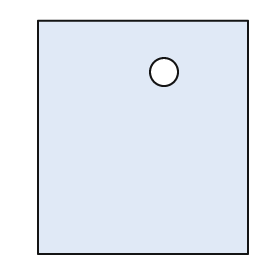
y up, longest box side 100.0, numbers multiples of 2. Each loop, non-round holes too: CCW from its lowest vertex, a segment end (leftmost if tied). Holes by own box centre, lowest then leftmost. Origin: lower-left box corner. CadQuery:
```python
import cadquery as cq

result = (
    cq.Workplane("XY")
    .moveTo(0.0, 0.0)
    .lineTo(90.0, 0.0)
    .lineTo(90.0, 100.0)
    .lineTo(0.0, 100.0)
    .close()
    .moveTo(54.0, 78.0)
    .circle(6.0)
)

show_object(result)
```